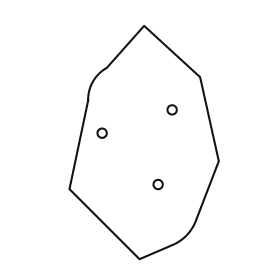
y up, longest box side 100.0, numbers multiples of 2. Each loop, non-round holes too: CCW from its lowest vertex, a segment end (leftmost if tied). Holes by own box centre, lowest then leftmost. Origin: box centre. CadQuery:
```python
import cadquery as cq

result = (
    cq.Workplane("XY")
    .moveTo(-2.0, -50.0)
    .lineTo(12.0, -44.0)
    .threePointArc((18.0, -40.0), (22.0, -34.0))
    .lineTo(32.0, -8.0)
    .lineTo(24.0, 28.0)
    .lineTo(0.0, 50.0)
    .lineTo(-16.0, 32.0)
    .threePointArc((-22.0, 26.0), (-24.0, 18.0))
    .lineTo(-32.0, -20.0)
    .close()
    .moveTo(6.0, -18.0)
    .circle(2.0)
    .moveTo(-18.0, 4.0)
    .circle(2.0)
    .moveTo(12.0, 14.0)
    .circle(2.0)
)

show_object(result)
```